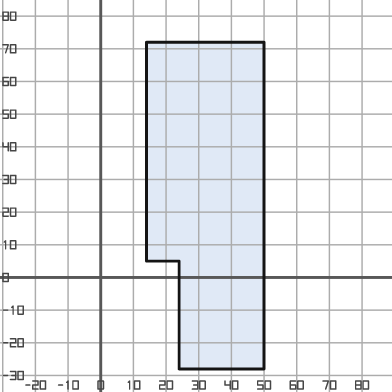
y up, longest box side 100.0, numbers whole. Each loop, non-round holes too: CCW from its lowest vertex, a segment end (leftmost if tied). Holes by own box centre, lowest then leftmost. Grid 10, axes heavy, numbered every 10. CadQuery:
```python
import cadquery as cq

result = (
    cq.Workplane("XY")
    .moveTo(24.0, -28.0)
    .lineTo(50.0, -28.0)
    .lineTo(50.0, 72.0)
    .lineTo(14.0, 72.0)
    .lineTo(14.0, 5.0)
    .lineTo(24.0, 5.0)
    .close()
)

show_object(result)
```